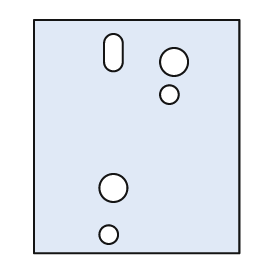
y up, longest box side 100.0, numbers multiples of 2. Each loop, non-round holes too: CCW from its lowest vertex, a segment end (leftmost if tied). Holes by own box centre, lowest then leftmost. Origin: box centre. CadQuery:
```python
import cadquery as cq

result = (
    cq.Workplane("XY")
    .moveTo(-44.0, -50.0)
    .lineTo(44.0, -50.0)
    .lineTo(44.0, 50.0)
    .lineTo(-44.0, 50.0)
    .close()
    .moveTo(-12.0, -42.0)
    .circle(4.0)
    .moveTo(-10.0, -22.0)
    .circle(6.0)
    .moveTo(14.0, 18.0)
    .circle(4.0)
    .moveTo(16.0, 32.0)
    .circle(6.0)
    .moveTo(-14.0, 32.0)
    .threePointArc((-10.0, 28.0), (-6.0, 32.0))
    .lineTo(-6.0, 40.0)
    .threePointArc((-10.0, 44.0), (-14.0, 40.0))
    .close()
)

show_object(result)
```